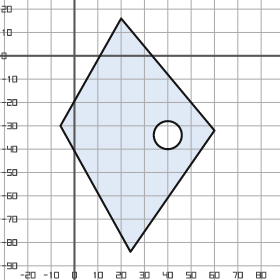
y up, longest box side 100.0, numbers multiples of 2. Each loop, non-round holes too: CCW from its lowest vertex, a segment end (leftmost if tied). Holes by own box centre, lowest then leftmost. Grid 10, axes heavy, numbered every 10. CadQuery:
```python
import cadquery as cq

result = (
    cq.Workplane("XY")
    .moveTo(24.0, -84.0)
    .lineTo(60.0, -32.0)
    .lineTo(20.0, 16.0)
    .lineTo(-6.0, -30.0)
    .close()
    .moveTo(40.0, -34.0)
    .circle(6.0)
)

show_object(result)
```